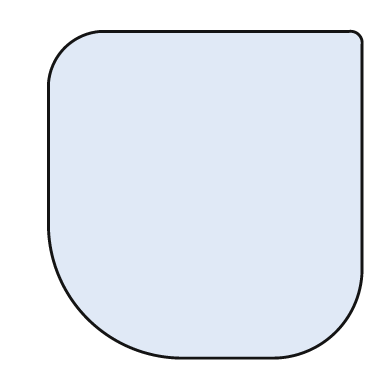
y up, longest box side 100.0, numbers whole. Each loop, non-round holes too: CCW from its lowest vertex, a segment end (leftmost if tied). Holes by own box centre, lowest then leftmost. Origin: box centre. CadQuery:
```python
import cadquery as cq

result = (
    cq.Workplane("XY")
    .moveTo(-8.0, -50.0)
    .lineTo(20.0, -50.0)
    .threePointArc((40.0, -42.0), (48.0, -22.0))
    .lineTo(48.0, 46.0)
    .threePointArc((47.0, 49.0), (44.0, 50.0))
    .lineTo(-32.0, 50.0)
    .threePointArc((-43.0, 45.0), (-48.0, 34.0))
    .lineTo(-48.0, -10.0)
    .threePointArc((-36.0, -38.0), (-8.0, -50.0))
    .close()
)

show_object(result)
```